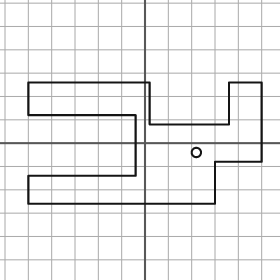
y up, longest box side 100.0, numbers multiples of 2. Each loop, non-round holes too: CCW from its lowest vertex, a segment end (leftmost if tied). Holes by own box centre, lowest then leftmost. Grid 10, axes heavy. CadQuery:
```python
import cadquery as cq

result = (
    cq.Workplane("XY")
    .moveTo(-50.0, -26.0)
    .lineTo(30.0, -26.0)
    .lineTo(30.0, -8.0)
    .lineTo(50.0, -8.0)
    .lineTo(50.0, 26.0)
    .lineTo(36.0, 26.0)
    .lineTo(36.0, 8.0)
    .lineTo(2.0, 8.0)
    .lineTo(2.0, 26.0)
    .lineTo(-50.0, 26.0)
    .lineTo(-50.0, 12.0)
    .lineTo(-4.0, 12.0)
    .lineTo(-4.0, -14.0)
    .lineTo(-50.0, -14.0)
    .close()
    .moveTo(22.0, -4.0)
    .circle(2.0)
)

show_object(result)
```